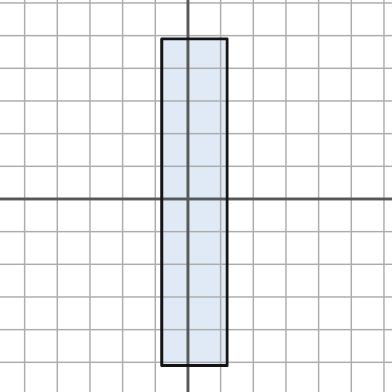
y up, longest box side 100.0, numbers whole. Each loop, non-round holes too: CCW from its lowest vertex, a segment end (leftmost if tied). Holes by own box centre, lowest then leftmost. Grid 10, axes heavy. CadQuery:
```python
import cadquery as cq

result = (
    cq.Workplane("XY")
    .moveTo(-8.0, -51.0)
    .lineTo(12.0, -51.0)
    .lineTo(12.0, 49.0)
    .lineTo(-8.0, 49.0)
    .close()
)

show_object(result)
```